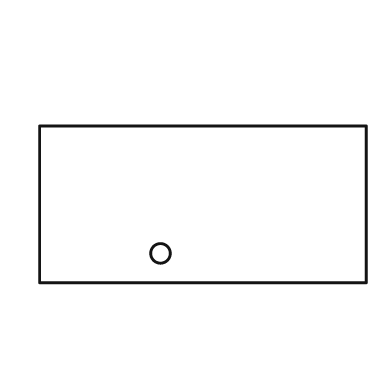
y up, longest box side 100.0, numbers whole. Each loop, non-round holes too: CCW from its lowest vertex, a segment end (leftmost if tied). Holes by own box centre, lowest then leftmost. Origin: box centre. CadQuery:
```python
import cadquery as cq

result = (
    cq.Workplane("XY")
    .moveTo(-50.0, -24.0)
    .lineTo(50.0, -24.0)
    .lineTo(50.0, 24.0)
    .lineTo(-50.0, 24.0)
    .close()
    .moveTo(-13.0, -15.0)
    .circle(3.0)
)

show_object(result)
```